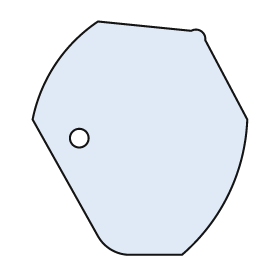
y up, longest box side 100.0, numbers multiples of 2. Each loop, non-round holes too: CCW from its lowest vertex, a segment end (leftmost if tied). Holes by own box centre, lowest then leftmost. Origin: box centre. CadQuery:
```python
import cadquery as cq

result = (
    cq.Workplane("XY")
    .moveTo(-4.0, -50.0)
    .lineTo(18.0, -50.0)
    .threePointArc((38.0, -24.0), (46.0, 8.0))
    .lineTo(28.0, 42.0)
    .threePointArc((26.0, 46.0), (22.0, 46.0))
    .lineTo(-18.0, 50.0)
    .threePointArc((-36.0, 32.0), (-46.0, 8.0))
    .lineTo(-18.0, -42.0)
    .threePointArc((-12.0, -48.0), (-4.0, -50.0))
    .close()
    .moveTo(-26.0, 0.0)
    .circle(4.0)
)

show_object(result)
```